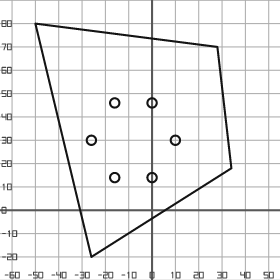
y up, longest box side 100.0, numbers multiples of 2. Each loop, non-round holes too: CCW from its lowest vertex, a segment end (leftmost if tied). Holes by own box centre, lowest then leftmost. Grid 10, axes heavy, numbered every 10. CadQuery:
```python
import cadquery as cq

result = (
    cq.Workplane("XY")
    .moveTo(-26.0, -20.0)
    .lineTo(34.0, 18.0)
    .lineTo(28.0, 70.0)
    .lineTo(-50.0, 80.0)
    .close()
    .moveTo(-16.0, 14.0)
    .circle(2.0)
    .moveTo(0.0, 14.0)
    .circle(2.0)
    .moveTo(-26.0, 30.0)
    .circle(2.0)
    .moveTo(10.0, 30.0)
    .circle(2.0)
    .moveTo(-16.0, 46.0)
    .circle(2.0)
    .moveTo(0.0, 46.0)
    .circle(2.0)
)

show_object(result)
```